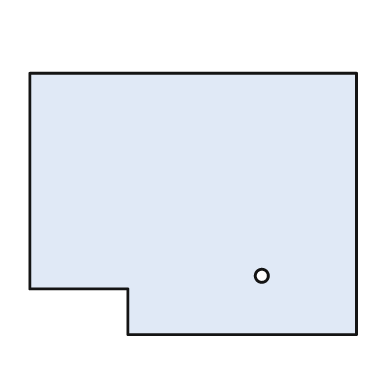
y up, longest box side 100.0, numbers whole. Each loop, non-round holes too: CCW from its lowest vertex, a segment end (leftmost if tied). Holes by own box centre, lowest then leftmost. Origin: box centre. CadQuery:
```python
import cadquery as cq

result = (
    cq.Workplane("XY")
    .moveTo(-20.0, -40.0)
    .lineTo(50.0, -40.0)
    .lineTo(50.0, 40.0)
    .lineTo(-50.0, 40.0)
    .lineTo(-50.0, -26.0)
    .lineTo(-20.0, -26.0)
    .close()
    .moveTo(21.0, -22.0)
    .circle(2.0)
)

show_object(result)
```